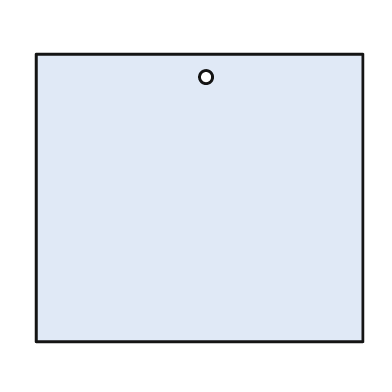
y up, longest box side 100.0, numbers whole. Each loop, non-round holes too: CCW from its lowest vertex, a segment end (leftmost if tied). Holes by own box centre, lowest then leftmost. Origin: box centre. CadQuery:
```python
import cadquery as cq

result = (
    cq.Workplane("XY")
    .moveTo(-50.0, -44.0)
    .lineTo(50.0, -44.0)
    .lineTo(50.0, 44.0)
    .lineTo(-50.0, 44.0)
    .close()
    .moveTo(2.0, 37.0)
    .circle(2.0)
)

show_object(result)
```